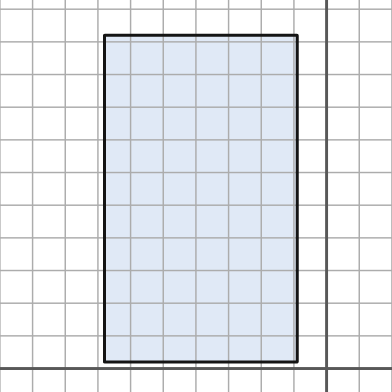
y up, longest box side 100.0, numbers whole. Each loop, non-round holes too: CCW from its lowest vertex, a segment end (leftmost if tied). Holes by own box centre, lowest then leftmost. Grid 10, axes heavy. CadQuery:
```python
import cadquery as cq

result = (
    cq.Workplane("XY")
    .moveTo(-68.0, 2.0)
    .lineTo(-9.0, 2.0)
    .lineTo(-9.0, 102.0)
    .lineTo(-68.0, 102.0)
    .close()
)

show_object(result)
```